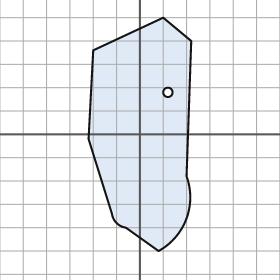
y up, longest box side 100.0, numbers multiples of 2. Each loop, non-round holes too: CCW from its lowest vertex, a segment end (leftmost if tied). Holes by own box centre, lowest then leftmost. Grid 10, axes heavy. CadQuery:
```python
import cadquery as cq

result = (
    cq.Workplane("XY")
    .moveTo(8.0, -50.0)
    .threePointArc((20.0, -36.0), (20.0, -18.0))
    .lineTo(22.0, 40.0)
    .lineTo(10.0, 50.0)
    .lineTo(-20.0, 36.0)
    .lineTo(-22.0, -2.0)
    .lineTo(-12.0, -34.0)
    .threePointArc((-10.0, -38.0), (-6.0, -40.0))
    .close()
    .moveTo(12.0, 18.0)
    .circle(2.0)
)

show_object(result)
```